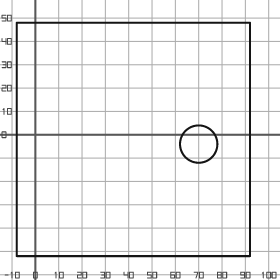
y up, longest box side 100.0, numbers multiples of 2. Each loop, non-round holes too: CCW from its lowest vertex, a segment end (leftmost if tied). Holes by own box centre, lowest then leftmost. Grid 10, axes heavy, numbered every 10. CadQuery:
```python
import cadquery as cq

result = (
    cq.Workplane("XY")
    .moveTo(-8.0, -52.0)
    .lineTo(92.0, -52.0)
    .lineTo(92.0, 48.0)
    .lineTo(-8.0, 48.0)
    .close()
    .moveTo(70.0, -4.0)
    .circle(8.0)
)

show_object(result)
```